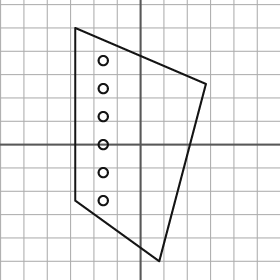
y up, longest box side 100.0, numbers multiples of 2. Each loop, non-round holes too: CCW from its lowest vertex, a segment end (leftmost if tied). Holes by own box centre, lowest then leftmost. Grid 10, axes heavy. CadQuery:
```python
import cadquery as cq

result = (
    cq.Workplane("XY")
    .moveTo(8.0, -50.0)
    .lineTo(28.0, 26.0)
    .lineTo(-28.0, 50.0)
    .lineTo(-28.0, -24.0)
    .close()
    .moveTo(-16.0, -24.0)
    .circle(2.0)
    .moveTo(-16.0, -12.0)
    .circle(2.0)
    .moveTo(-16.0, 0.0)
    .circle(2.0)
    .moveTo(-16.0, 12.0)
    .circle(2.0)
    .moveTo(-16.0, 24.0)
    .circle(2.0)
    .moveTo(-16.0, 36.0)
    .circle(2.0)
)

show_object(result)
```